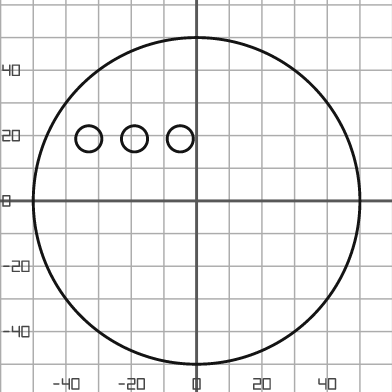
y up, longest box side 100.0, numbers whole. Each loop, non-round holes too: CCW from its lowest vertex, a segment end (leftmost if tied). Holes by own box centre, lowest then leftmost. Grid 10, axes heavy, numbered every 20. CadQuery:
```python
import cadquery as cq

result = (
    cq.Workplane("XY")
    .moveTo(0.0, 0.0)
    .circle(50.0)
    .moveTo(-33.0, 19.0)
    .circle(4.0)
    .moveTo(-19.0, 19.0)
    .circle(4.0)
    .moveTo(-5.0, 19.0)
    .circle(4.0)
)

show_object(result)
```